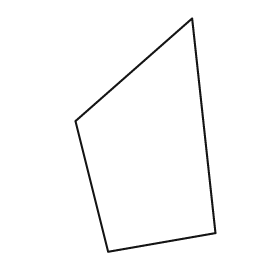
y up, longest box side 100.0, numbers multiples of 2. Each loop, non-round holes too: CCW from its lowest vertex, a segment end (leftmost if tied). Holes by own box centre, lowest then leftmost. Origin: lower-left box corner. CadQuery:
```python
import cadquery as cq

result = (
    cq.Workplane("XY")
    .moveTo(14.0, 0.0)
    .lineTo(60.0, 8.0)
    .lineTo(50.0, 100.0)
    .lineTo(0.0, 56.0)
    .close()
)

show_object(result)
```